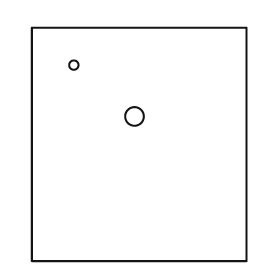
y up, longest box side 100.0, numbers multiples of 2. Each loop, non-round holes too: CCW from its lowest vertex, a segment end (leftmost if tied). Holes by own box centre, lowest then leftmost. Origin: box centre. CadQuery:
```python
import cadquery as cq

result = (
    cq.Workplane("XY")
    .moveTo(-46.0, -50.0)
    .lineTo(46.0, -50.0)
    .lineTo(46.0, 50.0)
    .lineTo(-46.0, 50.0)
    .close()
    .moveTo(-2.0, 12.0)
    .circle(4.0)
    .moveTo(-28.0, 34.0)
    .circle(2.0)
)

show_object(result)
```